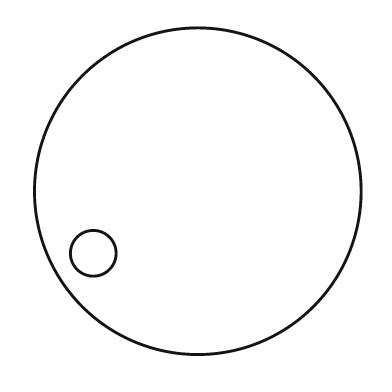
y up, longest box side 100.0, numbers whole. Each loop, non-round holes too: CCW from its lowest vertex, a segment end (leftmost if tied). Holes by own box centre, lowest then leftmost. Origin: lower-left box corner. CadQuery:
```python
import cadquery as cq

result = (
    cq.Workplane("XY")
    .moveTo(50.0, 50.0)
    .circle(50.0)
    .moveTo(18.0, 31.0)
    .circle(7.0)
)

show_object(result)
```